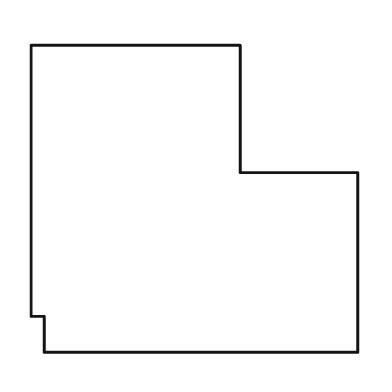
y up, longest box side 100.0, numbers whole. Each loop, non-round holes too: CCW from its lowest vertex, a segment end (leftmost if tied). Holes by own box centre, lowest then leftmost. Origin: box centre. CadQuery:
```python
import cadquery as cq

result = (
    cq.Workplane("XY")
    .moveTo(-46.0, -47.0)
    .lineTo(50.0, -47.0)
    .lineTo(50.0, 8.0)
    .lineTo(14.0, 8.0)
    .lineTo(14.0, 47.0)
    .lineTo(-50.0, 47.0)
    .lineTo(-50.0, -36.0)
    .lineTo(-46.0, -36.0)
    .close()
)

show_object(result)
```